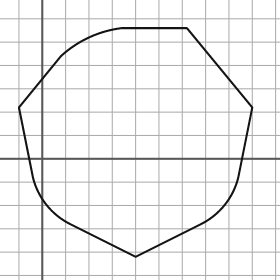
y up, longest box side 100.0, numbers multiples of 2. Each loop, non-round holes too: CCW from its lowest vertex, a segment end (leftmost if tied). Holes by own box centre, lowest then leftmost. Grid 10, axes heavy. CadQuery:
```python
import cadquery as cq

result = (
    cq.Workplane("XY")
    .moveTo(40.0, -42.0)
    .lineTo(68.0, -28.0)
    .threePointArc((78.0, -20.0), (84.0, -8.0))
    .lineTo(90.0, 22.0)
    .lineTo(62.0, 56.0)
    .lineTo(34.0, 56.0)
    .threePointArc((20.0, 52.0), (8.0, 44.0))
    .lineTo(-10.0, 22.0)
    .lineTo(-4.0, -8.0)
    .threePointArc((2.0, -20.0), (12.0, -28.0))
    .close()
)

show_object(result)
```